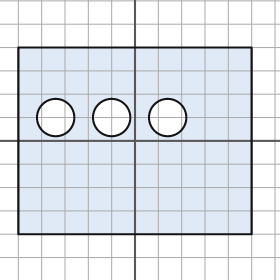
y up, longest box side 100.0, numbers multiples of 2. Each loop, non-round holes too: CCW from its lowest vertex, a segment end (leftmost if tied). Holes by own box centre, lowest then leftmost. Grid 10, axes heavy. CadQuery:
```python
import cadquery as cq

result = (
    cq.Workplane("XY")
    .moveTo(-50.0, -40.0)
    .lineTo(50.0, -40.0)
    .lineTo(50.0, 40.0)
    .lineTo(-50.0, 40.0)
    .close()
    .moveTo(-34.0, 10.0)
    .circle(8.0)
    .moveTo(-10.0, 10.0)
    .circle(8.0)
    .moveTo(14.0, 10.0)
    .circle(8.0)
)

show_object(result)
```